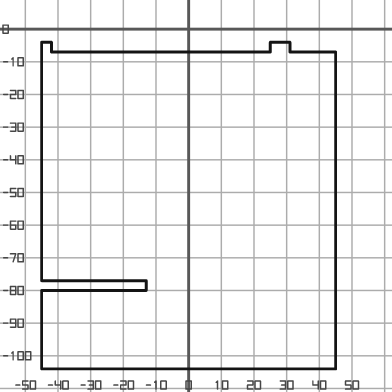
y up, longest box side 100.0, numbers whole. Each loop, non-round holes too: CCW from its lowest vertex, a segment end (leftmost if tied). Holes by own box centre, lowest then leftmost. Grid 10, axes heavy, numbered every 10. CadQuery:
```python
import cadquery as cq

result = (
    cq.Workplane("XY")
    .moveTo(-45.0, -104.0)
    .lineTo(45.0, -104.0)
    .lineTo(45.0, -7.0)
    .lineTo(31.0, -7.0)
    .lineTo(31.0, -4.0)
    .lineTo(25.0, -4.0)
    .lineTo(25.0, -7.0)
    .lineTo(-42.0, -7.0)
    .lineTo(-42.0, -4.0)
    .lineTo(-45.0, -4.0)
    .lineTo(-45.0, -77.0)
    .lineTo(-13.0, -77.0)
    .lineTo(-13.0, -80.0)
    .lineTo(-45.0, -80.0)
    .close()
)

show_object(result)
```